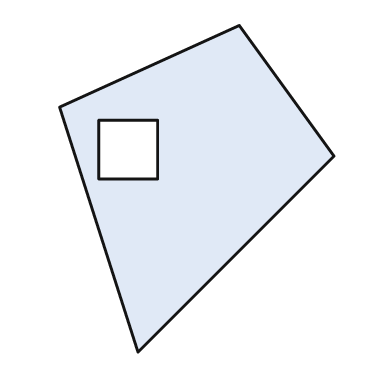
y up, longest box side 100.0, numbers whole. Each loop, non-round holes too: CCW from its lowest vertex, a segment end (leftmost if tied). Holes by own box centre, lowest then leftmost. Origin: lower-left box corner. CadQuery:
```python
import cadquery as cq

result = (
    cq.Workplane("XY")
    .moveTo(24.0, 0.0)
    .lineTo(84.0, 60.0)
    .lineTo(55.0, 100.0)
    .lineTo(0.0, 75.0)
    .close()
    .moveTo(12.0, 53.0)
    .lineTo(30.0, 53.0)
    .lineTo(30.0, 71.0)
    .lineTo(12.0, 71.0)
    .close()
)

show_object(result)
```